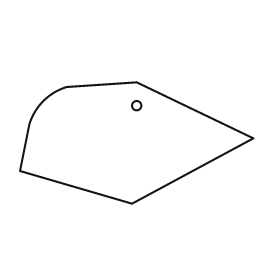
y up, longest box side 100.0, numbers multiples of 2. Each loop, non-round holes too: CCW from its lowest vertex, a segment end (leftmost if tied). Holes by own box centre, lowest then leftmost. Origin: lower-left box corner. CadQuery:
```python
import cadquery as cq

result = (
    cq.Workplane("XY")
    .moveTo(48.0, 0.0)
    .lineTo(100.0, 28.0)
    .lineTo(50.0, 52.0)
    .lineTo(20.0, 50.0)
    .threePointArc((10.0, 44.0), (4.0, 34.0))
    .lineTo(0.0, 14.0)
    .close()
    .moveTo(50.0, 42.0)
    .circle(2.0)
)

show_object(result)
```